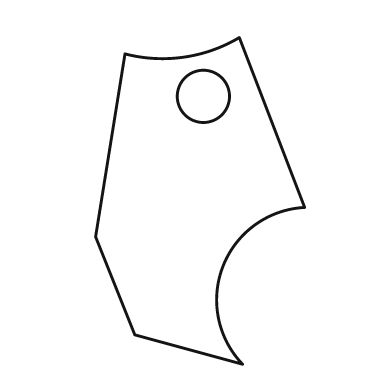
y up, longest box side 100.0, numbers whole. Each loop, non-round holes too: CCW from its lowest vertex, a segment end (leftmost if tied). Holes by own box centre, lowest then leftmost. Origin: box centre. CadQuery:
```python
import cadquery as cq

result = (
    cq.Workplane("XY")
    .moveTo(13.0, -50.0)
    .threePointArc((7.0, -20.0), (32.0, -2.0))
    .lineTo(12.0, 50.0)
    .threePointArc((-5.0, 44.0), (-23.0, 45.0))
    .lineTo(-32.0, -11.0)
    .lineTo(-20.0, -41.0)
    .close()
    .moveTo(1.0, 32.0)
    .circle(8.0)
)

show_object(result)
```